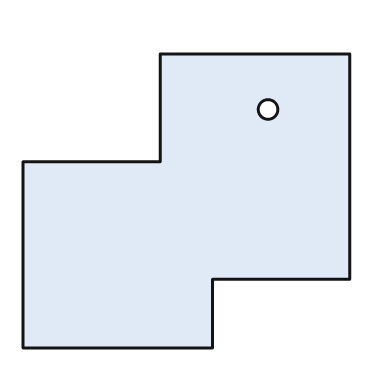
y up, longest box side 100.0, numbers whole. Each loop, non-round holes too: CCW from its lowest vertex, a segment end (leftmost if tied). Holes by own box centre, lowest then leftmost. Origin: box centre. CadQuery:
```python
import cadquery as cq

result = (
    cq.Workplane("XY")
    .moveTo(-50.0, -45.0)
    .lineTo(8.0, -45.0)
    .lineTo(8.0, -24.0)
    .lineTo(50.0, -24.0)
    .lineTo(50.0, 45.0)
    .lineTo(-8.0, 45.0)
    .lineTo(-8.0, 12.0)
    .lineTo(-50.0, 12.0)
    .close()
    .moveTo(25.0, 28.0)
    .circle(3.0)
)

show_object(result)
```